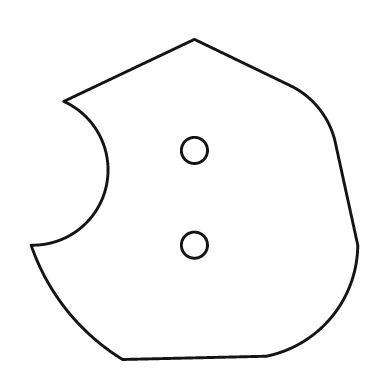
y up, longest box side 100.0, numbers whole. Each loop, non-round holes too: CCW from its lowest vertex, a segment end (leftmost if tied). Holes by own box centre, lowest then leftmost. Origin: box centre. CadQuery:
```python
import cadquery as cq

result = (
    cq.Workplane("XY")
    .moveTo(-22.0, -49.0)
    .lineTo(22.0, -48.0)
    .threePointArc((42.0, -36.0), (50.0, -14.0))
    .lineTo(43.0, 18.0)
    .threePointArc((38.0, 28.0), (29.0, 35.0))
    .lineTo(0.0, 49.0)
    .lineTo(-40.0, 30.0)
    .threePointArc((-27.0, 4.0), (-50.0, -14.0))
    .threePointArc((-39.0, -34.0), (-22.0, -49.0))
    .close()
    .moveTo(0.0, -14.0)
    .circle(4.0)
    .moveTo(0.0, 15.0)
    .circle(4.0)
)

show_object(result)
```